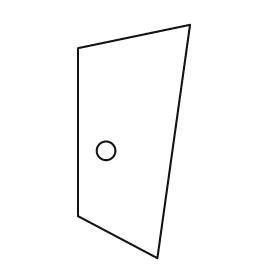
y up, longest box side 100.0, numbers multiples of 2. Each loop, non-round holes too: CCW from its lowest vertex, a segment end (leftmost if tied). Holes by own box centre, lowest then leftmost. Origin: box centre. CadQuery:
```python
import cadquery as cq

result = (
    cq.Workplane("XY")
    .moveTo(10.0, -50.0)
    .lineTo(24.0, 50.0)
    .lineTo(-24.0, 40.0)
    .lineTo(-24.0, -32.0)
    .close()
    .moveTo(-12.0, -4.0)
    .circle(4.0)
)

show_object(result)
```